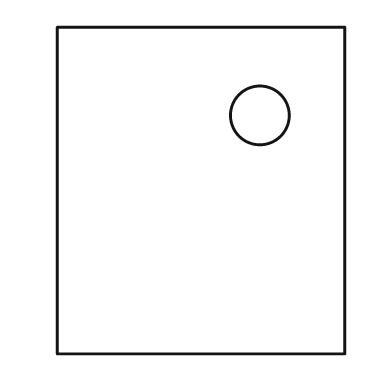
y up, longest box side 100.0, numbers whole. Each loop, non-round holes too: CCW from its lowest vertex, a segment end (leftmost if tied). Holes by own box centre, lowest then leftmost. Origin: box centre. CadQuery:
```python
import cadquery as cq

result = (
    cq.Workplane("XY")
    .moveTo(-44.0, -50.0)
    .lineTo(44.0, -50.0)
    .lineTo(44.0, 50.0)
    .lineTo(-44.0, 50.0)
    .close()
    .moveTo(18.0, 23.0)
    .circle(9.0)
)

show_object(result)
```